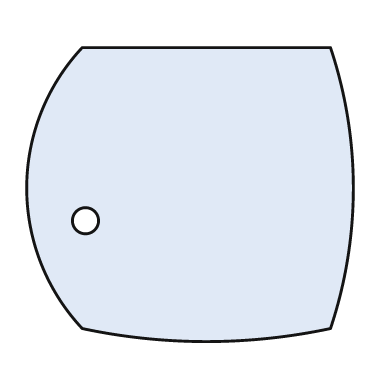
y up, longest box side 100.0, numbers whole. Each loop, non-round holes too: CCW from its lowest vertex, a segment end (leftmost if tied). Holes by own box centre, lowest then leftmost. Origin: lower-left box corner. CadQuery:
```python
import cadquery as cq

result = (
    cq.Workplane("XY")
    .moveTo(17.0, 4.0)
    .threePointArc((55.0, 0.0), (93.0, 4.0))
    .threePointArc((100.0, 47.0), (93.0, 90.0))
    .lineTo(17.0, 90.0)
    .threePointArc((0.0, 47.0), (17.0, 4.0))
    .close()
    .moveTo(18.0, 37.0)
    .circle(4.0)
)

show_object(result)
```